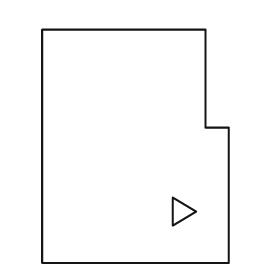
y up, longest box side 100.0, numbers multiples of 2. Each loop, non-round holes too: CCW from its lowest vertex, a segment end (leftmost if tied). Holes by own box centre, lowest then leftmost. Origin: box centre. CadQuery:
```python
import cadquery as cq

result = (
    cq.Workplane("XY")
    .moveTo(-40.0, -50.0)
    .lineTo(40.0, -50.0)
    .lineTo(40.0, 8.0)
    .lineTo(30.0, 8.0)
    .lineTo(30.0, 50.0)
    .lineTo(-40.0, 50.0)
    .close()
    .moveTo(16.0, -34.0)
    .lineTo(26.0, -28.0)
    .lineTo(16.0, -22.0)
    .close()
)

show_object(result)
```